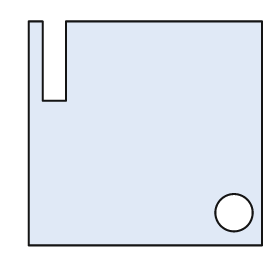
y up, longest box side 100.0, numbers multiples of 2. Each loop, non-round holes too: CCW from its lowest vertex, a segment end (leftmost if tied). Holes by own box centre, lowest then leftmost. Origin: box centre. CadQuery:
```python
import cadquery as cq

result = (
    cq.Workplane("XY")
    .moveTo(-50.0, -48.0)
    .lineTo(50.0, -48.0)
    .lineTo(50.0, 48.0)
    .lineTo(-34.0, 48.0)
    .lineTo(-34.0, 14.0)
    .lineTo(-44.0, 14.0)
    .lineTo(-44.0, 48.0)
    .lineTo(-50.0, 48.0)
    .close()
    .moveTo(38.0, -34.0)
    .circle(8.0)
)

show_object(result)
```